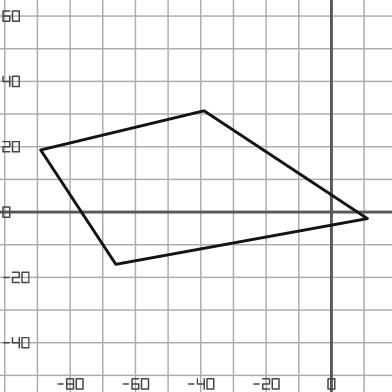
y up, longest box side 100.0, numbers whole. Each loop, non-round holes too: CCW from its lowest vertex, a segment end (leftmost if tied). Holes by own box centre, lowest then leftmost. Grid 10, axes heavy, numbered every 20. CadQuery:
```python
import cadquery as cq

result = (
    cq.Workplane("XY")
    .moveTo(-66.0, -16.0)
    .lineTo(11.0, -2.0)
    .lineTo(-39.0, 31.0)
    .lineTo(-89.0, 19.0)
    .close()
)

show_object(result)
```